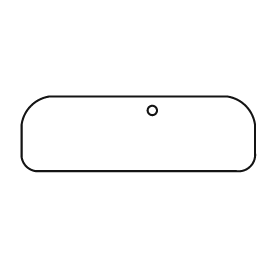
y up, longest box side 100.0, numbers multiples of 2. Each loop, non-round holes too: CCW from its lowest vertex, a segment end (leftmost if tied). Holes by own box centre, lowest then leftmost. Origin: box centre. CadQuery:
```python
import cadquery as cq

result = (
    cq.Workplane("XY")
    .moveTo(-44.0, -16.0)
    .lineTo(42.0, -16.0)
    .threePointArc((48.0, -14.0), (50.0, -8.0))
    .lineTo(50.0, 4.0)
    .threePointArc((46.0, 12.0), (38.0, 16.0))
    .lineTo(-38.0, 16.0)
    .threePointArc((-46.0, 12.0), (-50.0, 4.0))
    .lineTo(-50.0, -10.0)
    .threePointArc((-48.0, -14.0), (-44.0, -16.0))
    .close()
    .moveTo(6.0, 10.0)
    .circle(2.0)
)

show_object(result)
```